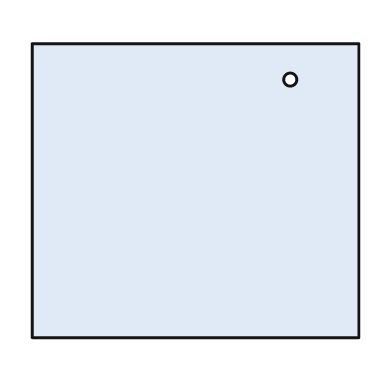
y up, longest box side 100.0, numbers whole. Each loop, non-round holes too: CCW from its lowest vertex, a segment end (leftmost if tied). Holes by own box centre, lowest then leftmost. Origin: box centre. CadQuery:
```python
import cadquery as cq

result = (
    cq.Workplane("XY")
    .moveTo(-50.0, -45.0)
    .lineTo(50.0, -45.0)
    .lineTo(50.0, 45.0)
    .lineTo(-50.0, 45.0)
    .close()
    .moveTo(29.0, 34.0)
    .circle(2.0)
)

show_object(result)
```